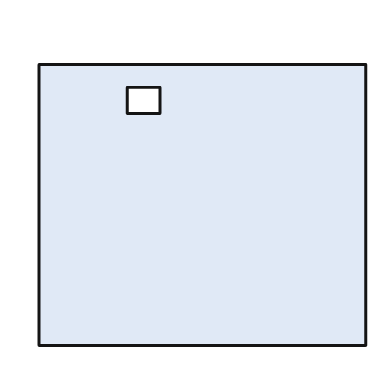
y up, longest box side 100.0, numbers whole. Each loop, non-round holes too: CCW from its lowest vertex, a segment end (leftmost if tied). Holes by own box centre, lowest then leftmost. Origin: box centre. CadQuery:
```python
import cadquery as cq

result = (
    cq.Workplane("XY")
    .moveTo(-50.0, -43.0)
    .lineTo(50.0, -43.0)
    .lineTo(50.0, 43.0)
    .lineTo(-50.0, 43.0)
    .close()
    .moveTo(-23.0, 28.0)
    .lineTo(-13.0, 28.0)
    .lineTo(-13.0, 36.0)
    .lineTo(-23.0, 36.0)
    .close()
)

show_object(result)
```